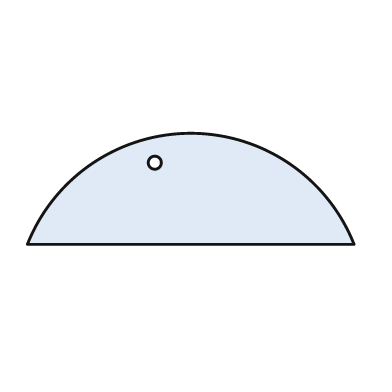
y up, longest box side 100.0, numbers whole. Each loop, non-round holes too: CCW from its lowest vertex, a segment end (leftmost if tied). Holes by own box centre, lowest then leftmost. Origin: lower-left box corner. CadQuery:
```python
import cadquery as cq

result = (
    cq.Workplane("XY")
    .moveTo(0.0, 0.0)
    .lineTo(100.0, 0.0)
    .threePointArc((50.0, 34.0), (0.0, 0.0))
    .close()
    .moveTo(39.0, 25.0)
    .circle(2.0)
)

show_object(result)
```